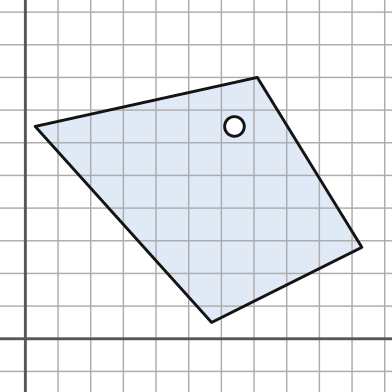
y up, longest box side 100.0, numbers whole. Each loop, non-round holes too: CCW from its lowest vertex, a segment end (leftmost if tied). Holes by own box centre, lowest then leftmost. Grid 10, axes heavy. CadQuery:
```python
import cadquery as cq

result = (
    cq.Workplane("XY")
    .moveTo(57.0, 5.0)
    .lineTo(103.0, 28.0)
    .lineTo(71.0, 80.0)
    .lineTo(3.0, 65.0)
    .close()
    .moveTo(64.0, 65.0)
    .circle(3.0)
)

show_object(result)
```